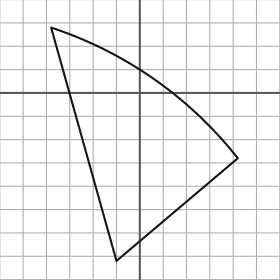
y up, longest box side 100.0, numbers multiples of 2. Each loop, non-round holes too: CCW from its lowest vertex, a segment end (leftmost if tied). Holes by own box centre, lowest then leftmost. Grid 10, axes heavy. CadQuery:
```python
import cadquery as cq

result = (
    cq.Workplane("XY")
    .moveTo(-10.0, -72.0)
    .lineTo(42.0, -28.0)
    .threePointArc((6.0, 6.0), (-38.0, 28.0))
    .close()
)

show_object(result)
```